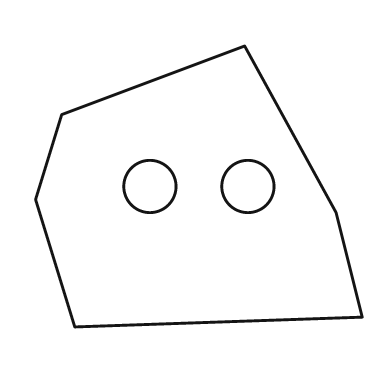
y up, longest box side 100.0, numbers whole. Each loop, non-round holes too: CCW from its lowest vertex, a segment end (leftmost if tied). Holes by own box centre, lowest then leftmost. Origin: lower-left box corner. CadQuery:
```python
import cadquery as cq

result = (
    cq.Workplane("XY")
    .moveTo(12.0, 0.0)
    .lineTo(100.0, 3.0)
    .lineTo(92.0, 35.0)
    .lineTo(64.0, 86.0)
    .lineTo(8.0, 65.0)
    .lineTo(0.0, 39.0)
    .close()
    .moveTo(35.0, 43.0)
    .circle(8.0)
    .moveTo(65.0, 43.0)
    .circle(8.0)
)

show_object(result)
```